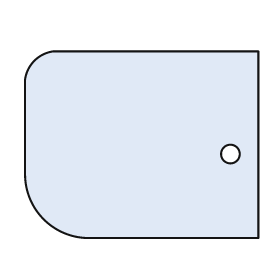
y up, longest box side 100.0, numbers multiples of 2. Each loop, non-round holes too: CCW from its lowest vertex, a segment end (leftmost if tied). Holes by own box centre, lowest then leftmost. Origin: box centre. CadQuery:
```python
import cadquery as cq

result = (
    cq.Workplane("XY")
    .moveTo(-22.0, -40.0)
    .lineTo(50.0, -40.0)
    .lineTo(50.0, 40.0)
    .lineTo(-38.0, 40.0)
    .threePointArc((-46.0, 36.0), (-50.0, 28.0))
    .lineTo(-50.0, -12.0)
    .threePointArc((-42.0, -32.0), (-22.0, -40.0))
    .close()
    .moveTo(38.0, -4.0)
    .circle(4.0)
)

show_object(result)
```